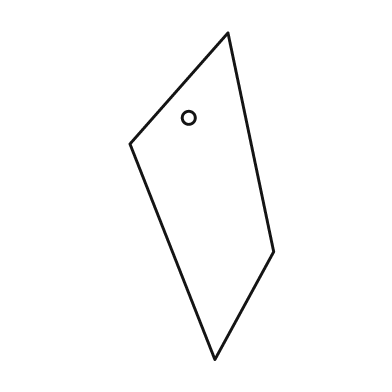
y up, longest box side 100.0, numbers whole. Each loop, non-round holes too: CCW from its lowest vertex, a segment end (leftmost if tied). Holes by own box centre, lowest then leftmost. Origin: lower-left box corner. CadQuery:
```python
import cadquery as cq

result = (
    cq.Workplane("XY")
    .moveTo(26.0, 0.0)
    .lineTo(44.0, 33.0)
    .lineTo(30.0, 100.0)
    .lineTo(0.0, 66.0)
    .close()
    .moveTo(18.0, 74.0)
    .circle(2.0)
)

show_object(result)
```